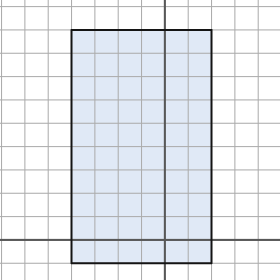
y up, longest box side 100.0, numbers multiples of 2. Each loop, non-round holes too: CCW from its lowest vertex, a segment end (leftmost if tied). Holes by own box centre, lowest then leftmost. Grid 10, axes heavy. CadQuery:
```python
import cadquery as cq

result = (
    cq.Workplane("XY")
    .moveTo(-40.0, -10.0)
    .lineTo(20.0, -10.0)
    .lineTo(20.0, 90.0)
    .lineTo(-40.0, 90.0)
    .close()
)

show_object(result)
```